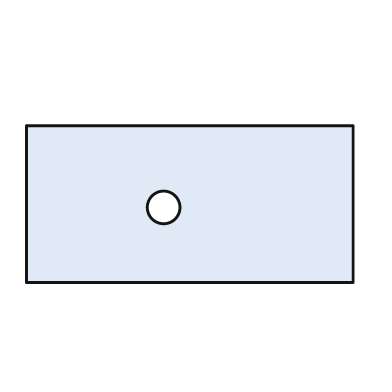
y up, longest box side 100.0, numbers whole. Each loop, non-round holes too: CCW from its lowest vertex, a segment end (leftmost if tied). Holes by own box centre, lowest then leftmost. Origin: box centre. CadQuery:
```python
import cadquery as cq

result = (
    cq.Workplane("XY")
    .moveTo(-50.0, -24.0)
    .lineTo(50.0, -24.0)
    .lineTo(50.0, 24.0)
    .lineTo(-50.0, 24.0)
    .close()
    .moveTo(-8.0, -1.0)
    .circle(5.0)
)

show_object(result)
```